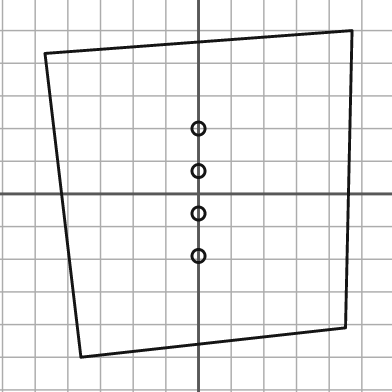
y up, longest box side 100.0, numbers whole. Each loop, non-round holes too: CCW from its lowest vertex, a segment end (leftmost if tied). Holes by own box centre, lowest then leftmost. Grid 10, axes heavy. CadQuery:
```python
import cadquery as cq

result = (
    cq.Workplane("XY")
    .moveTo(-36.0, -50.0)
    .lineTo(45.0, -41.0)
    .lineTo(47.0, 50.0)
    .lineTo(-47.0, 43.0)
    .close()
    .moveTo(0.0, -19.0)
    .circle(2.0)
    .moveTo(0.0, -6.0)
    .circle(2.0)
    .moveTo(0.0, 7.0)
    .circle(2.0)
    .moveTo(0.0, 20.0)
    .circle(2.0)
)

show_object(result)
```